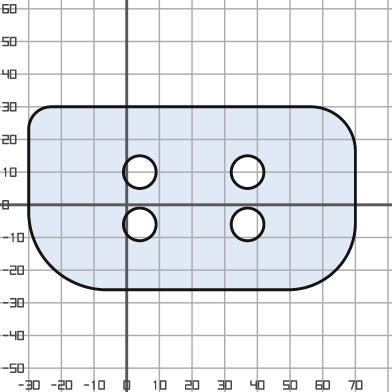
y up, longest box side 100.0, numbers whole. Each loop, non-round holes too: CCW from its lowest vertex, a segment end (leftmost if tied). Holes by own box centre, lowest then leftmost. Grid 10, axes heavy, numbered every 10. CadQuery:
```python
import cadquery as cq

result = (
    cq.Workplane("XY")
    .moveTo(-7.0, -26.0)
    .lineTo(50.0, -26.0)
    .threePointArc((64.0, -20.0), (70.0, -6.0))
    .lineTo(70.0, 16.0)
    .threePointArc((66.0, 26.0), (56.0, 30.0))
    .lineTo(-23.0, 30.0)
    .threePointArc((-28.0, 28.0), (-30.0, 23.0))
    .lineTo(-30.0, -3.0)
    .threePointArc((-23.0, -19.0), (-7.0, -26.0))
    .close()
    .moveTo(4.0, -6.0)
    .circle(5.0)
    .moveTo(37.0, -6.0)
    .circle(5.0)
    .moveTo(4.0, 10.0)
    .circle(5.0)
    .moveTo(37.0, 10.0)
    .circle(5.0)
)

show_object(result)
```